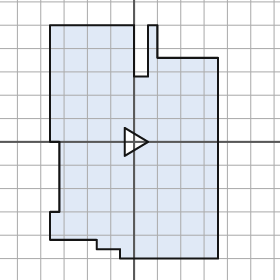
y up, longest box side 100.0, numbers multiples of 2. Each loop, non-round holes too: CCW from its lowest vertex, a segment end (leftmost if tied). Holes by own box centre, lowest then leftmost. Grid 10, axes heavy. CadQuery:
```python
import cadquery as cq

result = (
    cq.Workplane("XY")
    .moveTo(-6.0, -50.0)
    .lineTo(36.0, -50.0)
    .lineTo(36.0, 36.0)
    .lineTo(10.0, 36.0)
    .lineTo(10.0, 50.0)
    .lineTo(6.0, 50.0)
    .lineTo(6.0, 28.0)
    .lineTo(0.0, 28.0)
    .lineTo(0.0, 50.0)
    .lineTo(-36.0, 50.0)
    .lineTo(-36.0, 0.0)
    .lineTo(-32.0, 0.0)
    .lineTo(-32.0, -30.0)
    .lineTo(-36.0, -30.0)
    .lineTo(-36.0, -42.0)
    .lineTo(-16.0, -42.0)
    .lineTo(-16.0, -46.0)
    .lineTo(-6.0, -46.0)
    .close()
    .moveTo(-4.0, -6.0)
    .lineTo(6.0, 0.0)
    .lineTo(-4.0, 6.0)
    .close()
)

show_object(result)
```